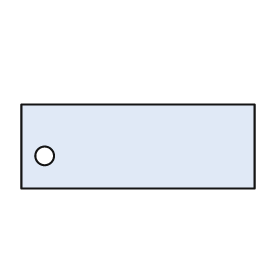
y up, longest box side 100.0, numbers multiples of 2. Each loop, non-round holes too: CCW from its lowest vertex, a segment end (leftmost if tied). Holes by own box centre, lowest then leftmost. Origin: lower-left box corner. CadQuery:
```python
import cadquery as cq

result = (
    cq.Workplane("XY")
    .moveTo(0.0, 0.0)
    .lineTo(100.0, 0.0)
    .lineTo(100.0, 36.0)
    .lineTo(0.0, 36.0)
    .close()
    .moveTo(10.0, 14.0)
    .circle(4.0)
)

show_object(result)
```